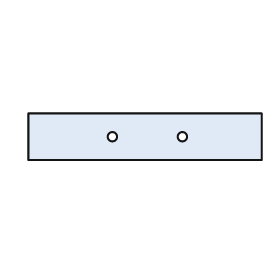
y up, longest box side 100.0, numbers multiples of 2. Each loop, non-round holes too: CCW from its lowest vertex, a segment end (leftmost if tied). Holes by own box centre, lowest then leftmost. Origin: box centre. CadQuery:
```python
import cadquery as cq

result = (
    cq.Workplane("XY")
    .moveTo(-50.0, -10.0)
    .lineTo(50.0, -10.0)
    .lineTo(50.0, 10.0)
    .lineTo(-50.0, 10.0)
    .close()
    .moveTo(-14.0, 0.0)
    .circle(2.0)
    .moveTo(16.0, 0.0)
    .circle(2.0)
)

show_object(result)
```